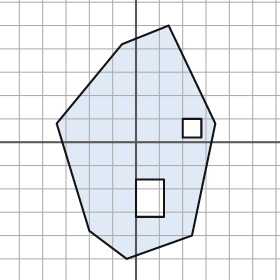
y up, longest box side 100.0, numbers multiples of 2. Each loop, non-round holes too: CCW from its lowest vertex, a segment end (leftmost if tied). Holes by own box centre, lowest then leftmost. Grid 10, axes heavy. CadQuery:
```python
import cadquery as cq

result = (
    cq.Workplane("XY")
    .moveTo(-4.0, -50.0)
    .lineTo(24.0, -40.0)
    .lineTo(34.0, 8.0)
    .lineTo(14.0, 50.0)
    .lineTo(-6.0, 42.0)
    .lineTo(-34.0, 8.0)
    .lineTo(-20.0, -38.0)
    .close()
    .moveTo(0.0, -32.0)
    .lineTo(12.0, -32.0)
    .lineTo(12.0, -16.0)
    .lineTo(0.0, -16.0)
    .close()
    .moveTo(20.0, 2.0)
    .lineTo(28.0, 2.0)
    .lineTo(28.0, 10.0)
    .lineTo(20.0, 10.0)
    .close()
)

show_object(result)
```